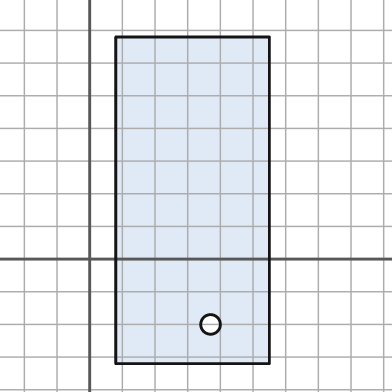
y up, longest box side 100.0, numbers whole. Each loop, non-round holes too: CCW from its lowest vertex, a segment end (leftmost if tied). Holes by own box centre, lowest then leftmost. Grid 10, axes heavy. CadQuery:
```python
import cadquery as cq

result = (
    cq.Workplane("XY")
    .moveTo(8.0, -32.0)
    .lineTo(55.0, -32.0)
    .lineTo(55.0, 68.0)
    .lineTo(8.0, 68.0)
    .close()
    .moveTo(37.0, -20.0)
    .circle(3.0)
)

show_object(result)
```